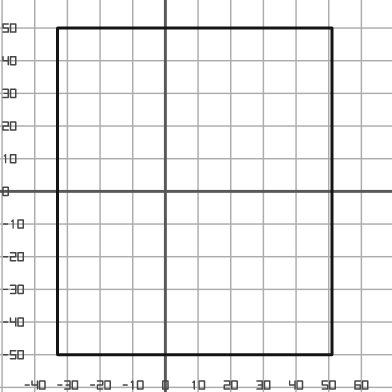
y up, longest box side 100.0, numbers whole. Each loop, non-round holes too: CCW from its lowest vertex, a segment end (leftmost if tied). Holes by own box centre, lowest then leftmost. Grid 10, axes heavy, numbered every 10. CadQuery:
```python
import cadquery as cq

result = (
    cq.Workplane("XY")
    .moveTo(-33.0, -50.0)
    .lineTo(51.0, -50.0)
    .lineTo(51.0, 50.0)
    .lineTo(-33.0, 50.0)
    .close()
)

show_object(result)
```